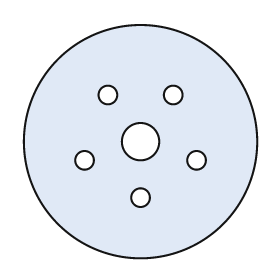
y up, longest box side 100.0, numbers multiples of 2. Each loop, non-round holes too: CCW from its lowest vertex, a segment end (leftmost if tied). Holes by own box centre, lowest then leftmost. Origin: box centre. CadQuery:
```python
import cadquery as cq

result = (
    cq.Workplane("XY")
    .moveTo(0.0, 0.0)
    .circle(50.0)
    .moveTo(0.0, -24.0)
    .circle(4.0)
    .moveTo(-24.0, -8.0)
    .circle(4.0)
    .moveTo(24.0, -8.0)
    .circle(4.0)
    .moveTo(0.0, 0.0)
    .circle(8.0)
    .moveTo(-14.0, 20.0)
    .circle(4.0)
    .moveTo(14.0, 20.0)
    .circle(4.0)
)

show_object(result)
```